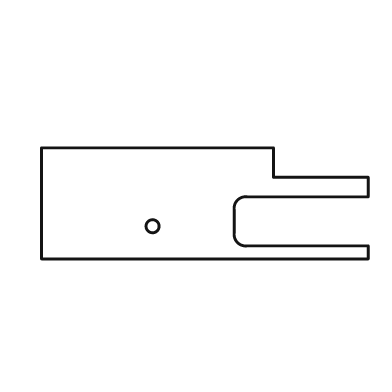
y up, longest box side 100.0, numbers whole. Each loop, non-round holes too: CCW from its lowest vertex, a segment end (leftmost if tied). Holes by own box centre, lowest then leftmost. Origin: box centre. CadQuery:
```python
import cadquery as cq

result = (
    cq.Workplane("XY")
    .moveTo(-50.0, -17.0)
    .lineTo(50.0, -17.0)
    .lineTo(50.0, -13.0)
    .lineTo(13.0, -13.0)
    .threePointArc((10.0, -12.0), (9.0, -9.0))
    .lineTo(9.0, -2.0)
    .threePointArc((10.0, 1.0), (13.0, 2.0))
    .lineTo(50.0, 2.0)
    .lineTo(50.0, 8.0)
    .lineTo(21.0, 8.0)
    .lineTo(21.0, 17.0)
    .lineTo(-50.0, 17.0)
    .close()
    .moveTo(-16.0, -7.0)
    .circle(2.0)
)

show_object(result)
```